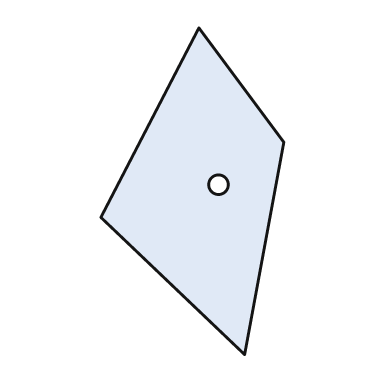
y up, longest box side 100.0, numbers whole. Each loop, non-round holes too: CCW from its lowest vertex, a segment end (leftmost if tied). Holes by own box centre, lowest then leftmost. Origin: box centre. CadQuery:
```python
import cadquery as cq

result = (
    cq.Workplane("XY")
    .moveTo(16.0, -50.0)
    .lineTo(28.0, 15.0)
    .lineTo(2.0, 50.0)
    .lineTo(-28.0, -8.0)
    .close()
    .moveTo(8.0, 2.0)
    .circle(3.0)
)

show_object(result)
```